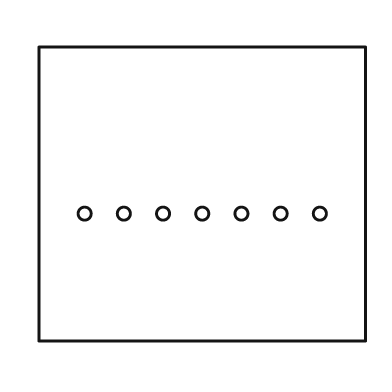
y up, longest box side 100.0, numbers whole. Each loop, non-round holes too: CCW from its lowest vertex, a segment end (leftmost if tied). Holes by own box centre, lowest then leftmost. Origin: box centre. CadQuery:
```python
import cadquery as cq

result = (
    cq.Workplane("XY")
    .moveTo(-50.0, -45.0)
    .lineTo(50.0, -45.0)
    .lineTo(50.0, 45.0)
    .lineTo(-50.0, 45.0)
    .close()
    .moveTo(-36.0, -6.0)
    .circle(2.0)
    .moveTo(-24.0, -6.0)
    .circle(2.0)
    .moveTo(-12.0, -6.0)
    .circle(2.0)
    .moveTo(0.0, -6.0)
    .circle(2.0)
    .moveTo(12.0, -6.0)
    .circle(2.0)
    .moveTo(24.0, -6.0)
    .circle(2.0)
    .moveTo(36.0, -6.0)
    .circle(2.0)
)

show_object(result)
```